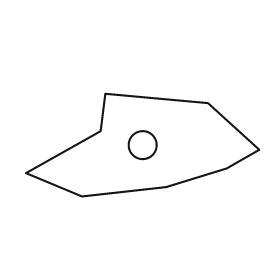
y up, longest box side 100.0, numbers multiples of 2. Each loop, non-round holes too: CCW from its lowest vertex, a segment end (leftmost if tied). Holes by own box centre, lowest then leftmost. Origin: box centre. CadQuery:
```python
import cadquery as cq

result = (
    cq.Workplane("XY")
    .moveTo(-26.0, -22.0)
    .lineTo(10.0, -18.0)
    .lineTo(36.0, -10.0)
    .lineTo(50.0, -2.0)
    .lineTo(28.0, 18.0)
    .lineTo(-16.0, 22.0)
    .lineTo(-18.0, 6.0)
    .lineTo(-50.0, -12.0)
    .close()
    .moveTo(0.0, 0.0)
    .circle(6.0)
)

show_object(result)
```